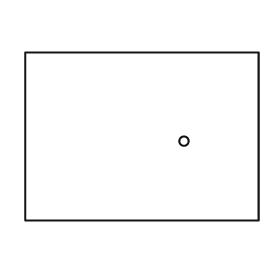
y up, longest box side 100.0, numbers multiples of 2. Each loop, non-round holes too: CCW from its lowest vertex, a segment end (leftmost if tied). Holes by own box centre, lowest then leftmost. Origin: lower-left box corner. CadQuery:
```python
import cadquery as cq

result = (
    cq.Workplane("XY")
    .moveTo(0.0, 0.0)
    .lineTo(100.0, 0.0)
    .lineTo(100.0, 72.0)
    .lineTo(0.0, 72.0)
    .close()
    .moveTo(68.0, 34.0)
    .circle(2.0)
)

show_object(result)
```